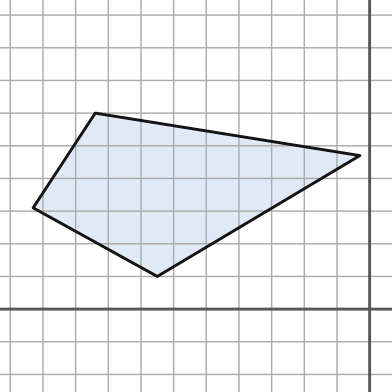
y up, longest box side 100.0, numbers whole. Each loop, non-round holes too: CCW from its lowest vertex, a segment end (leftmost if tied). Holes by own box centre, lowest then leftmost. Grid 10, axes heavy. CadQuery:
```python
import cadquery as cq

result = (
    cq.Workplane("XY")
    .moveTo(-65.0, 10.0)
    .lineTo(-3.0, 47.0)
    .lineTo(-84.0, 60.0)
    .lineTo(-103.0, 31.0)
    .close()
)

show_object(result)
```